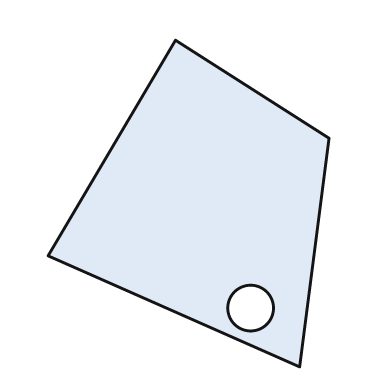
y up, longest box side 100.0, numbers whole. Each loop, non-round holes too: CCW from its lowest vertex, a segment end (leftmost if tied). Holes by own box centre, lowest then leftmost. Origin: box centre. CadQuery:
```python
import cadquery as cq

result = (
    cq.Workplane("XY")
    .moveTo(34.0, -50.0)
    .lineTo(43.0, 20.0)
    .lineTo(-4.0, 50.0)
    .lineTo(-43.0, -16.0)
    .close()
    .moveTo(19.0, -32.0)
    .circle(7.0)
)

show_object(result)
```